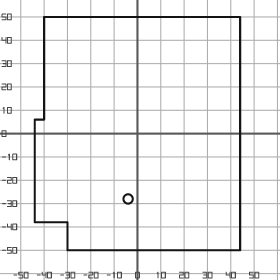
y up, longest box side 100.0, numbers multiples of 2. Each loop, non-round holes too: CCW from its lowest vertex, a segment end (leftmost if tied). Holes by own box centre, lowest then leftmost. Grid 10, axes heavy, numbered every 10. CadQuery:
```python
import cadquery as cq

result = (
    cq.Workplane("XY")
    .moveTo(-30.0, -50.0)
    .lineTo(44.0, -50.0)
    .lineTo(44.0, 50.0)
    .lineTo(-40.0, 50.0)
    .lineTo(-40.0, 6.0)
    .lineTo(-44.0, 6.0)
    .lineTo(-44.0, -38.0)
    .lineTo(-30.0, -38.0)
    .close()
    .moveTo(-4.0, -28.0)
    .circle(2.0)
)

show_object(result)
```